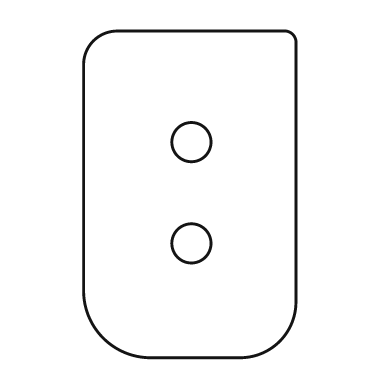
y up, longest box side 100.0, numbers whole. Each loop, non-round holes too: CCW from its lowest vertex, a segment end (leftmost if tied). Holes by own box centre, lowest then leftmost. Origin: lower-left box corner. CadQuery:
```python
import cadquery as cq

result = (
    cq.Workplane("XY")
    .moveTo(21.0, 0.0)
    .lineTo(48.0, 0.0)
    .threePointArc((60.0, 5.0), (65.0, 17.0))
    .lineTo(65.0, 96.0)
    .threePointArc((64.0, 99.0), (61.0, 100.0))
    .lineTo(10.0, 100.0)
    .threePointArc((3.0, 97.0), (0.0, 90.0))
    .lineTo(0.0, 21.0)
    .threePointArc((6.0, 6.0), (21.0, 0.0))
    .close()
    .moveTo(33.0, 35.0)
    .circle(6.0)
    .moveTo(33.0, 66.0)
    .circle(6.0)
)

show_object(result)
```